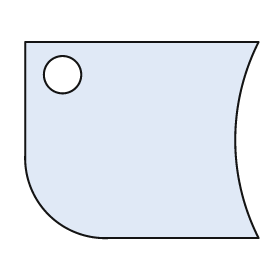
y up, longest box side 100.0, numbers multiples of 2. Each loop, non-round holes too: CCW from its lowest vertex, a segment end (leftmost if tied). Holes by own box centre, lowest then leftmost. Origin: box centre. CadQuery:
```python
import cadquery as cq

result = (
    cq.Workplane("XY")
    .moveTo(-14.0, -42.0)
    .lineTo(50.0, -42.0)
    .threePointArc((40.0, 0.0), (50.0, 42.0))
    .lineTo(-50.0, 42.0)
    .lineTo(-50.0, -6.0)
    .threePointArc((-40.0, -32.0), (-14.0, -42.0))
    .close()
    .moveTo(-34.0, 28.0)
    .circle(8.0)
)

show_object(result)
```